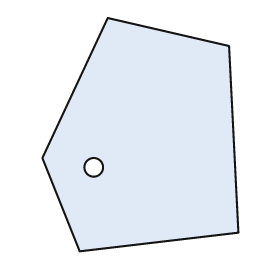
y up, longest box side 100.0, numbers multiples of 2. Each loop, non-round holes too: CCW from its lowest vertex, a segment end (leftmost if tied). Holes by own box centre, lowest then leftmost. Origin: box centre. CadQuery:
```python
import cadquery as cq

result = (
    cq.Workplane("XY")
    .moveTo(-26.0, -50.0)
    .lineTo(42.0, -42.0)
    .lineTo(38.0, 38.0)
    .lineTo(-14.0, 50.0)
    .lineTo(-42.0, -10.0)
    .close()
    .moveTo(-20.0, -14.0)
    .circle(4.0)
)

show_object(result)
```